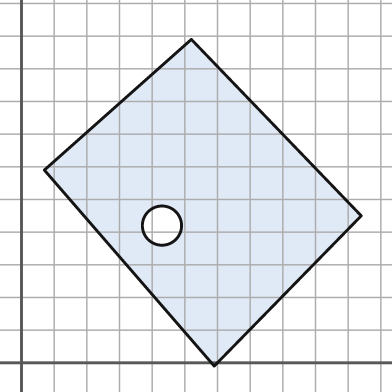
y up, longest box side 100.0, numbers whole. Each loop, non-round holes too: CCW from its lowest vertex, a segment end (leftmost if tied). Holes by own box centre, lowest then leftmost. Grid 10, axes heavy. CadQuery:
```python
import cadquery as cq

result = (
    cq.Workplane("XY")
    .moveTo(59.0, -1.0)
    .lineTo(104.0, 45.0)
    .lineTo(52.0, 99.0)
    .lineTo(7.0, 59.0)
    .close()
    .moveTo(43.0, 42.0)
    .circle(6.0)
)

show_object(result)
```